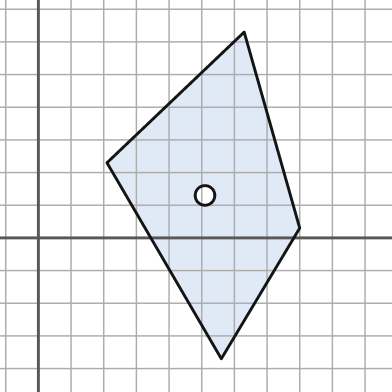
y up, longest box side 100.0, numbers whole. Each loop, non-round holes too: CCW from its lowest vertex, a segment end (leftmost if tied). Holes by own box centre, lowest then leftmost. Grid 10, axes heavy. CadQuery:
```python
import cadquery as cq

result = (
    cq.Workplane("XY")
    .moveTo(56.0, -37.0)
    .lineTo(80.0, 3.0)
    .lineTo(63.0, 63.0)
    .lineTo(21.0, 23.0)
    .close()
    .moveTo(51.0, 13.0)
    .circle(3.0)
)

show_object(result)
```